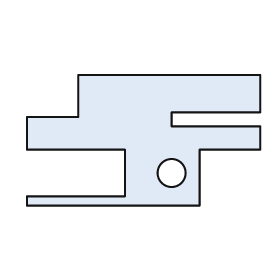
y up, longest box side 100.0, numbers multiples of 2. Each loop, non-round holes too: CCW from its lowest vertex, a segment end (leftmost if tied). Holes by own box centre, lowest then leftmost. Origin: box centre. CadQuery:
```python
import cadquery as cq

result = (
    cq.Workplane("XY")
    .moveTo(-50.0, -28.0)
    .lineTo(24.0, -28.0)
    .lineTo(24.0, -4.0)
    .lineTo(50.0, -4.0)
    .lineTo(50.0, 6.0)
    .lineTo(12.0, 6.0)
    .lineTo(12.0, 12.0)
    .lineTo(50.0, 12.0)
    .lineTo(50.0, 28.0)
    .lineTo(-28.0, 28.0)
    .lineTo(-28.0, 10.0)
    .lineTo(-50.0, 10.0)
    .lineTo(-50.0, -4.0)
    .lineTo(-8.0, -4.0)
    .lineTo(-8.0, -24.0)
    .lineTo(-50.0, -24.0)
    .close()
    .moveTo(12.0, -14.0)
    .circle(6.0)
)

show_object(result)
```